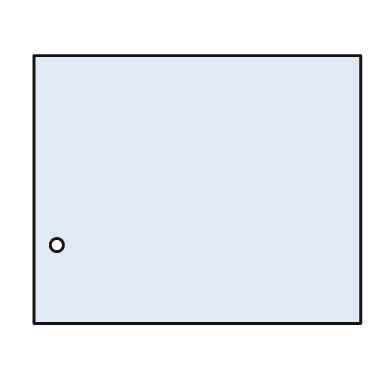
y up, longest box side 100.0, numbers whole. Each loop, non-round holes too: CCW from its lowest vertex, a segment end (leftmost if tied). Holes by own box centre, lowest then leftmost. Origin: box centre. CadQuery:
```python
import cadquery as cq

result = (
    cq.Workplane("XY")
    .moveTo(-50.0, -41.0)
    .lineTo(50.0, -41.0)
    .lineTo(50.0, 41.0)
    .lineTo(-50.0, 41.0)
    .close()
    .moveTo(-43.0, -17.0)
    .circle(2.0)
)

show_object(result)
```